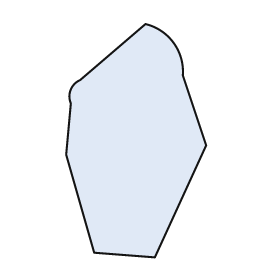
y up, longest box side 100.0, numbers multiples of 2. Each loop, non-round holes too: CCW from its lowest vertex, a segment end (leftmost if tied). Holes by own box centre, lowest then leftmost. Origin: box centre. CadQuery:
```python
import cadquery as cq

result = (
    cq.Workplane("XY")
    .moveTo(8.0, -50.0)
    .lineTo(30.0, -2.0)
    .lineTo(20.0, 28.0)
    .threePointArc((16.0, 42.0), (4.0, 50.0))
    .lineTo(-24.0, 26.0)
    .threePointArc((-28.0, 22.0), (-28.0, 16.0))
    .lineTo(-30.0, -6.0)
    .lineTo(-18.0, -48.0)
    .close()
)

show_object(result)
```